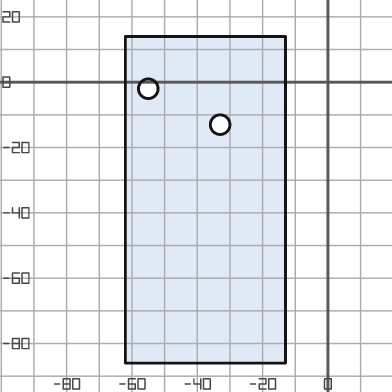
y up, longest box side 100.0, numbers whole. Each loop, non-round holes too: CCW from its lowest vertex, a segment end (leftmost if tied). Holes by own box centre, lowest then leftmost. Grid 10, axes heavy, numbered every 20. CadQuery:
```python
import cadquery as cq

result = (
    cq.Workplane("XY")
    .moveTo(-62.0, -86.0)
    .lineTo(-13.0, -86.0)
    .lineTo(-13.0, 14.0)
    .lineTo(-62.0, 14.0)
    .close()
    .moveTo(-33.0, -13.0)
    .circle(3.0)
    .moveTo(-55.0, -2.0)
    .circle(3.0)
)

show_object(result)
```